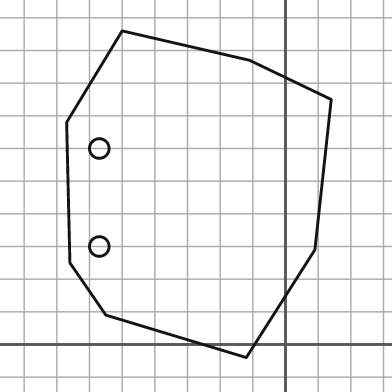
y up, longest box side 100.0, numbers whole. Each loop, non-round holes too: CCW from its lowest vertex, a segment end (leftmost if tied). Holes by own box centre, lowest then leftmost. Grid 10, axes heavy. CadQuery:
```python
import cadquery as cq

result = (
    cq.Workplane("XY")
    .moveTo(-12.0, -4.0)
    .lineTo(9.0, 29.0)
    .lineTo(14.0, 75.0)
    .lineTo(-11.0, 87.0)
    .lineTo(-50.0, 96.0)
    .lineTo(-67.0, 68.0)
    .lineTo(-66.0, 25.0)
    .lineTo(-55.0, 9.0)
    .close()
    .moveTo(-57.0, 30.0)
    .circle(3.0)
    .moveTo(-57.0, 60.0)
    .circle(3.0)
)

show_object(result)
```